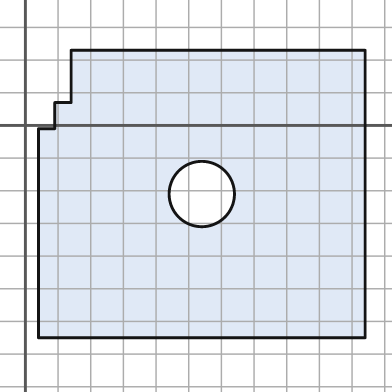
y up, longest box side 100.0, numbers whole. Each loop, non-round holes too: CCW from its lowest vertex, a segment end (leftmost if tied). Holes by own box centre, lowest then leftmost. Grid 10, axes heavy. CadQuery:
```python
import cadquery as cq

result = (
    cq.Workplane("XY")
    .moveTo(4.0, -65.0)
    .lineTo(104.0, -65.0)
    .lineTo(104.0, 23.0)
    .lineTo(14.0, 23.0)
    .lineTo(14.0, 7.0)
    .lineTo(9.0, 7.0)
    .lineTo(9.0, -1.0)
    .lineTo(4.0, -1.0)
    .close()
    .moveTo(54.0, -21.0)
    .circle(10.0)
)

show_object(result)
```